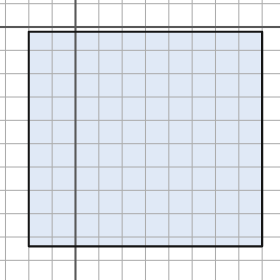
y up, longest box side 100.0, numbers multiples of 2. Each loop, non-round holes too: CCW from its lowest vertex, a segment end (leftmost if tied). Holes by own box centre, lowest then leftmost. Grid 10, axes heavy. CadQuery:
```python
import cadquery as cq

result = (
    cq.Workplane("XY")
    .moveTo(-20.0, -94.0)
    .lineTo(80.0, -94.0)
    .lineTo(80.0, -2.0)
    .lineTo(-20.0, -2.0)
    .close()
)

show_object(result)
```